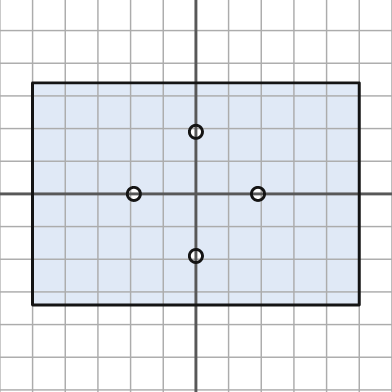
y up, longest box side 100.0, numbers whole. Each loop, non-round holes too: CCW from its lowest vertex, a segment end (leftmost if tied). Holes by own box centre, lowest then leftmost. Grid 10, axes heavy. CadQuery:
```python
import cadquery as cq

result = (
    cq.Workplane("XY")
    .moveTo(-50.0, -34.0)
    .lineTo(50.0, -34.0)
    .lineTo(50.0, 34.0)
    .lineTo(-50.0, 34.0)
    .close()
    .moveTo(0.0, -19.0)
    .circle(2.0)
    .moveTo(-19.0, 0.0)
    .circle(2.0)
    .moveTo(19.0, 0.0)
    .circle(2.0)
    .moveTo(0.0, 19.0)
    .circle(2.0)
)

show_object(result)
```